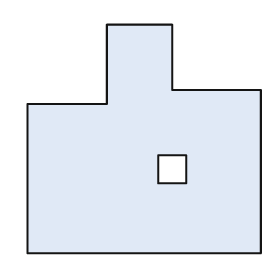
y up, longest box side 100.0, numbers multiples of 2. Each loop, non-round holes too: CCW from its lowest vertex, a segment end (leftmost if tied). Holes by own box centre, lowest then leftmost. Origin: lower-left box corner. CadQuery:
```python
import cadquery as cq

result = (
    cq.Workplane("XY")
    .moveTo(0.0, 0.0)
    .lineTo(100.0, 0.0)
    .lineTo(100.0, 70.0)
    .lineTo(62.0, 70.0)
    .lineTo(62.0, 98.0)
    .lineTo(34.0, 98.0)
    .lineTo(34.0, 64.0)
    .lineTo(0.0, 64.0)
    .close()
    .moveTo(56.0, 30.0)
    .lineTo(68.0, 30.0)
    .lineTo(68.0, 42.0)
    .lineTo(56.0, 42.0)
    .close()
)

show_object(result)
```